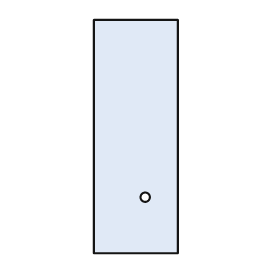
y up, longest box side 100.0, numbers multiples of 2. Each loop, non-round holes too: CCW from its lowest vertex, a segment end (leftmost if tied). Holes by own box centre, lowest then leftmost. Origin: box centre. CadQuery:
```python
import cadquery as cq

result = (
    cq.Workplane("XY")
    .moveTo(-18.0, -50.0)
    .lineTo(18.0, -50.0)
    .lineTo(18.0, 50.0)
    .lineTo(-18.0, 50.0)
    .close()
    .moveTo(4.0, -26.0)
    .circle(2.0)
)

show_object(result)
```